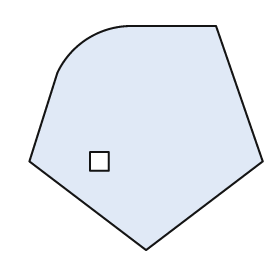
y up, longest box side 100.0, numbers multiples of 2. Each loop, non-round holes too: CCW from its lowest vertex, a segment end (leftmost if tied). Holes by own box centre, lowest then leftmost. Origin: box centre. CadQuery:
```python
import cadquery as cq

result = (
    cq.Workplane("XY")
    .moveTo(0.0, -48.0)
    .lineTo(50.0, -10.0)
    .lineTo(30.0, 48.0)
    .lineTo(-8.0, 48.0)
    .threePointArc((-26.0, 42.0), (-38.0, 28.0))
    .lineTo(-50.0, -10.0)
    .close()
    .moveTo(-24.0, -14.0)
    .lineTo(-16.0, -14.0)
    .lineTo(-16.0, -6.0)
    .lineTo(-24.0, -6.0)
    .close()
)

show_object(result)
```